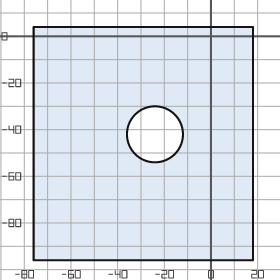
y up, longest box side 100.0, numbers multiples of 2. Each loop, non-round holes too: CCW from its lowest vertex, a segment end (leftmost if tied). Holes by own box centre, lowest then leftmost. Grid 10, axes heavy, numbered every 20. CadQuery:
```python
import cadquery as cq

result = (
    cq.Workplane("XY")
    .moveTo(-76.0, -96.0)
    .lineTo(18.0, -96.0)
    .lineTo(18.0, 4.0)
    .lineTo(-76.0, 4.0)
    .close()
    .moveTo(-24.0, -42.0)
    .circle(12.0)
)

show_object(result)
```